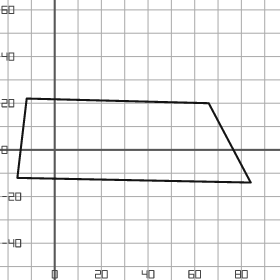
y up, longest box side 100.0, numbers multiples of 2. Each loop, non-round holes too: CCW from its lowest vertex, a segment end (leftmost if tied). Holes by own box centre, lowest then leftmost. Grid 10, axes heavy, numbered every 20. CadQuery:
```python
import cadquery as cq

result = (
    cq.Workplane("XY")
    .moveTo(84.0, -14.0)
    .lineTo(66.0, 20.0)
    .lineTo(-12.0, 22.0)
    .lineTo(-16.0, -12.0)
    .close()
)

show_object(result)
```